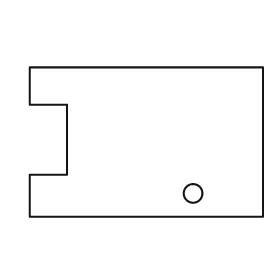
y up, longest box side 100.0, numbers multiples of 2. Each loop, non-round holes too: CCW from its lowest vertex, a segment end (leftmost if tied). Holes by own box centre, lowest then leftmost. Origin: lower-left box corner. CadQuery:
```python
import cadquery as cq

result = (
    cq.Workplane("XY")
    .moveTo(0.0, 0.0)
    .lineTo(100.0, 0.0)
    .lineTo(100.0, 64.0)
    .lineTo(0.0, 64.0)
    .lineTo(0.0, 48.0)
    .lineTo(16.0, 48.0)
    .lineTo(16.0, 18.0)
    .lineTo(0.0, 18.0)
    .close()
    .moveTo(70.0, 10.0)
    .circle(4.0)
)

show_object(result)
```